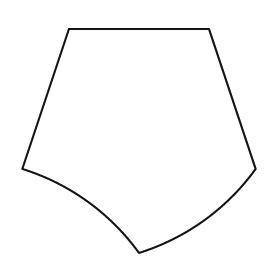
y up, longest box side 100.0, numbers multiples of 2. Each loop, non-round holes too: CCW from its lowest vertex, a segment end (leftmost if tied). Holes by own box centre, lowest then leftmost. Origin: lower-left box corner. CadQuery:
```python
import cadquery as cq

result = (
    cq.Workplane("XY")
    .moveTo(50.0, 0.0)
    .threePointArc((78.0, 14.0), (100.0, 36.0))
    .lineTo(80.0, 96.0)
    .lineTo(20.0, 96.0)
    .lineTo(0.0, 36.0)
    .threePointArc((28.0, 22.0), (50.0, 0.0))
    .close()
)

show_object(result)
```